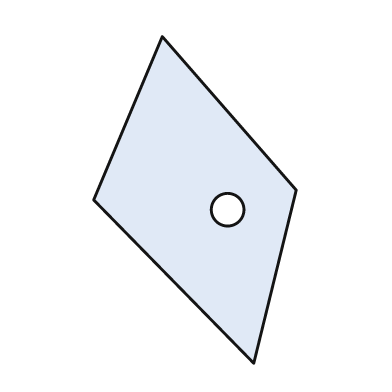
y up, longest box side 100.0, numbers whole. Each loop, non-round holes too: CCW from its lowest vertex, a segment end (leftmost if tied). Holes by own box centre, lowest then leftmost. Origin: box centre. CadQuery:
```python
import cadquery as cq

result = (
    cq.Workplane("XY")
    .moveTo(18.0, -50.0)
    .lineTo(31.0, 3.0)
    .lineTo(-10.0, 50.0)
    .lineTo(-31.0, 0.0)
    .close()
    .moveTo(10.0, -3.0)
    .circle(5.0)
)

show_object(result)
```